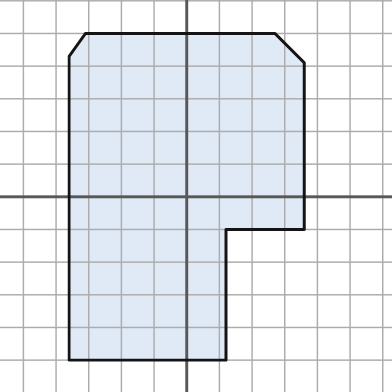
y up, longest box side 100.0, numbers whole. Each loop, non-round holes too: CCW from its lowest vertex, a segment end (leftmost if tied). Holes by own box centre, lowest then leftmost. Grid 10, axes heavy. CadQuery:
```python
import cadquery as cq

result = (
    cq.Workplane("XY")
    .moveTo(-36.0, -50.0)
    .lineTo(12.0, -50.0)
    .lineTo(12.0, -10.0)
    .lineTo(36.0, -10.0)
    .lineTo(36.0, 41.0)
    .lineTo(27.0, 50.0)
    .lineTo(-31.0, 50.0)
    .lineTo(-36.0, 43.0)
    .close()
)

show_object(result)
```